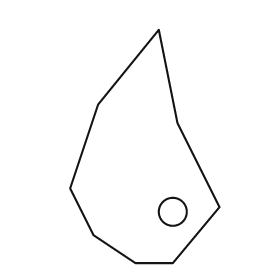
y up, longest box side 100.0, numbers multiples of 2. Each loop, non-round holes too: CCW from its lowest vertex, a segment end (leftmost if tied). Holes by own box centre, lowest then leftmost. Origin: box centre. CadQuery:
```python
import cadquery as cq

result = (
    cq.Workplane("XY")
    .moveTo(-4.0, -50.0)
    .lineTo(12.0, -50.0)
    .lineTo(32.0, -26.0)
    .lineTo(14.0, 10.0)
    .lineTo(6.0, 50.0)
    .lineTo(-20.0, 18.0)
    .lineTo(-32.0, -18.0)
    .lineTo(-22.0, -38.0)
    .close()
    .moveTo(12.0, -28.0)
    .circle(6.0)
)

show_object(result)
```